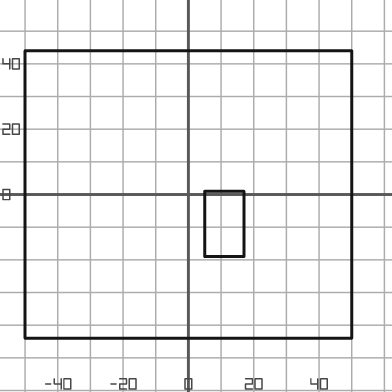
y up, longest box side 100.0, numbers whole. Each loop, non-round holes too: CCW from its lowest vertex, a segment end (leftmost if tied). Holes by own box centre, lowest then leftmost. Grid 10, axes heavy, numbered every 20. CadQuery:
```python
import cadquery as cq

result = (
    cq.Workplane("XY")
    .moveTo(-50.0, -44.0)
    .lineTo(50.0, -44.0)
    .lineTo(50.0, 44.0)
    .lineTo(-50.0, 44.0)
    .close()
    .moveTo(5.0, -19.0)
    .lineTo(17.0, -19.0)
    .lineTo(17.0, 1.0)
    .lineTo(5.0, 1.0)
    .close()
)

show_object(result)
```